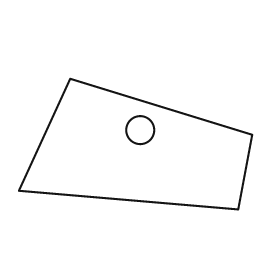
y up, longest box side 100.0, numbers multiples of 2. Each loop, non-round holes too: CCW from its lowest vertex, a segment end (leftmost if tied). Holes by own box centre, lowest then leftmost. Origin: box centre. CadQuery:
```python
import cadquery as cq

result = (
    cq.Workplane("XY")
    .moveTo(44.0, -28.0)
    .lineTo(50.0, 4.0)
    .lineTo(-28.0, 28.0)
    .lineTo(-50.0, -20.0)
    .close()
    .moveTo(2.0, 6.0)
    .circle(6.0)
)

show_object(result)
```